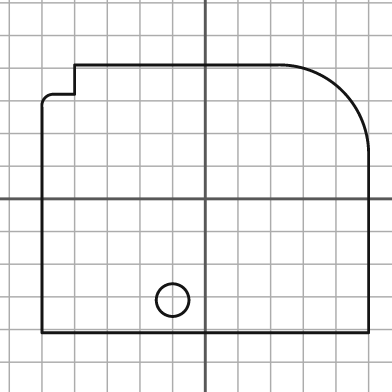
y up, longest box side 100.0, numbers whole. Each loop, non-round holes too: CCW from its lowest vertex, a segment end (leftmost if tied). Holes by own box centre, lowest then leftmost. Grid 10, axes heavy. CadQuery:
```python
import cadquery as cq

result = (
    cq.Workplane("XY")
    .moveTo(-50.0, -41.0)
    .lineTo(50.0, -41.0)
    .lineTo(50.0, 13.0)
    .threePointArc((42.0, 33.0), (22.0, 41.0))
    .lineTo(-40.0, 41.0)
    .lineTo(-40.0, 32.0)
    .lineTo(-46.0, 32.0)
    .threePointArc((-49.0, 31.0), (-50.0, 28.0))
    .close()
    .moveTo(-10.0, -31.0)
    .circle(5.0)
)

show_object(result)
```